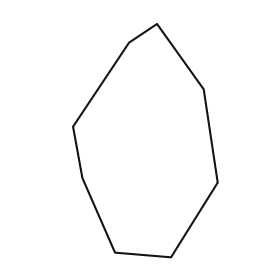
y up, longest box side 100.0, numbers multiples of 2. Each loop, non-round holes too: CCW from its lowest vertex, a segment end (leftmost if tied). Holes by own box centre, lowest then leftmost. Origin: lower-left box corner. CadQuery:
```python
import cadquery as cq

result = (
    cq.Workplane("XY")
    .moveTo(42.0, 0.0)
    .lineTo(62.0, 32.0)
    .lineTo(56.0, 72.0)
    .lineTo(36.0, 100.0)
    .lineTo(24.0, 92.0)
    .lineTo(0.0, 56.0)
    .lineTo(4.0, 34.0)
    .lineTo(18.0, 2.0)
    .close()
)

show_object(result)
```